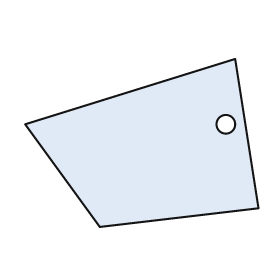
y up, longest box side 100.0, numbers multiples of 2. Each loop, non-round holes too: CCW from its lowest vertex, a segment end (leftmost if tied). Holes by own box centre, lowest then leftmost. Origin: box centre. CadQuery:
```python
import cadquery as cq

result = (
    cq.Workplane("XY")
    .moveTo(-18.0, -36.0)
    .lineTo(50.0, -28.0)
    .lineTo(40.0, 36.0)
    .lineTo(-50.0, 8.0)
    .close()
    .moveTo(36.0, 8.0)
    .circle(4.0)
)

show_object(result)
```